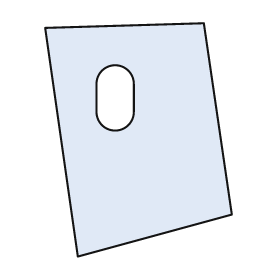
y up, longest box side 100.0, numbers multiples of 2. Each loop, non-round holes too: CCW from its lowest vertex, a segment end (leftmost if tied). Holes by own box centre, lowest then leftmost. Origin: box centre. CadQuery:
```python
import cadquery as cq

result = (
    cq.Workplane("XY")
    .moveTo(-26.0, -50.0)
    .lineTo(40.0, -32.0)
    .lineTo(28.0, 50.0)
    .lineTo(-40.0, 48.0)
    .close()
    .moveTo(-18.0, 12.0)
    .threePointArc((-10.0, 4.0), (-2.0, 12.0))
    .lineTo(-2.0, 24.0)
    .threePointArc((-10.0, 32.0), (-18.0, 24.0))
    .close()
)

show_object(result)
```